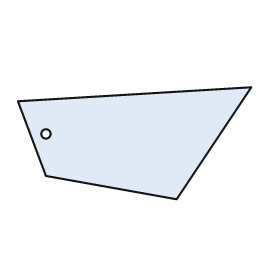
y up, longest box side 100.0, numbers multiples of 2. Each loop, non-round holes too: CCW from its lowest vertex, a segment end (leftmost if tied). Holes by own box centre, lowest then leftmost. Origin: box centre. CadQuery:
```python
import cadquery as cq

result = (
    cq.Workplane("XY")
    .moveTo(18.0, -24.0)
    .lineTo(50.0, 24.0)
    .lineTo(-50.0, 18.0)
    .lineTo(-38.0, -14.0)
    .close()
    .moveTo(-38.0, 4.0)
    .circle(2.0)
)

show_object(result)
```